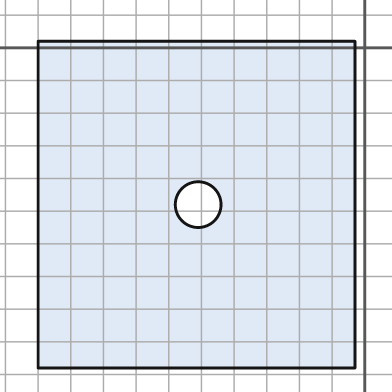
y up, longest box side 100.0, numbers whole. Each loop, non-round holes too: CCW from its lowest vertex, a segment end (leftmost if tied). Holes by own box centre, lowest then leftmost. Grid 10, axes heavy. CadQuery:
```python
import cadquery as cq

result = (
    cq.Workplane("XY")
    .moveTo(-100.0, -98.0)
    .lineTo(-3.0, -98.0)
    .lineTo(-3.0, 2.0)
    .lineTo(-100.0, 2.0)
    .close()
    .moveTo(-51.0, -48.0)
    .circle(7.0)
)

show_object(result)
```